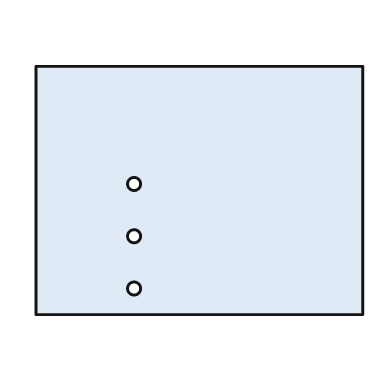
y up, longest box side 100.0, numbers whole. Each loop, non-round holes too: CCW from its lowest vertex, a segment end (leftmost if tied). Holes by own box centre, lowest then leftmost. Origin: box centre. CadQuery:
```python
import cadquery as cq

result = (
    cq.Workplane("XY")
    .moveTo(-50.0, -38.0)
    .lineTo(50.0, -38.0)
    .lineTo(50.0, 38.0)
    .lineTo(-50.0, 38.0)
    .close()
    .moveTo(-20.0, -30.0)
    .circle(2.0)
    .moveTo(-20.0, -14.0)
    .circle(2.0)
    .moveTo(-20.0, 2.0)
    .circle(2.0)
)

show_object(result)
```